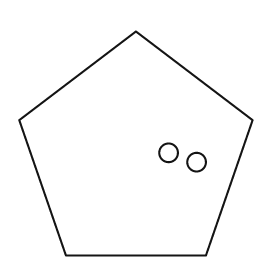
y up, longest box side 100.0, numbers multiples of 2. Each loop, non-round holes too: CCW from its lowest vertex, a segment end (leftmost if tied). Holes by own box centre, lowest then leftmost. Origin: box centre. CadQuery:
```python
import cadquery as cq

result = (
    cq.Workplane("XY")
    .moveTo(-30.0, -48.0)
    .lineTo(30.0, -48.0)
    .lineTo(50.0, 10.0)
    .lineTo(0.0, 48.0)
    .lineTo(-50.0, 10.0)
    .close()
    .moveTo(26.0, -8.0)
    .circle(4.0)
    .moveTo(14.0, -4.0)
    .circle(4.0)
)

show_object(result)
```